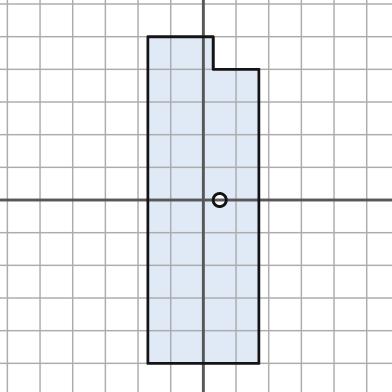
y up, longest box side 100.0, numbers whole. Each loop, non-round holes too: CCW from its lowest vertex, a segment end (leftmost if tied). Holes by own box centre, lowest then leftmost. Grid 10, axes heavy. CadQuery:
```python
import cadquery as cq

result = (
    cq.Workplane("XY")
    .moveTo(-17.0, -50.0)
    .lineTo(17.0, -50.0)
    .lineTo(17.0, 40.0)
    .lineTo(3.0, 40.0)
    .lineTo(3.0, 50.0)
    .lineTo(-17.0, 50.0)
    .close()
    .moveTo(5.0, 0.0)
    .circle(2.0)
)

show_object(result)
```